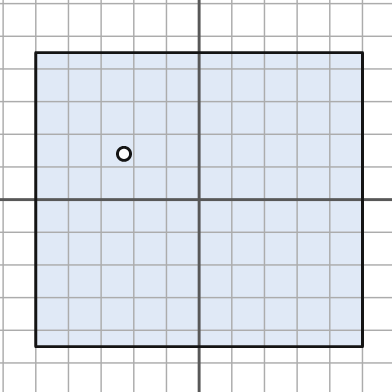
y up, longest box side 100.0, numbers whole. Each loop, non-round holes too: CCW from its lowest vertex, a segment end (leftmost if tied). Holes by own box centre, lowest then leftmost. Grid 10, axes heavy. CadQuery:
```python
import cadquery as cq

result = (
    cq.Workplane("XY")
    .moveTo(-50.0, -45.0)
    .lineTo(50.0, -45.0)
    .lineTo(50.0, 45.0)
    .lineTo(-50.0, 45.0)
    .close()
    .moveTo(-23.0, 14.0)
    .circle(2.0)
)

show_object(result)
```